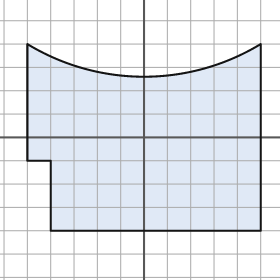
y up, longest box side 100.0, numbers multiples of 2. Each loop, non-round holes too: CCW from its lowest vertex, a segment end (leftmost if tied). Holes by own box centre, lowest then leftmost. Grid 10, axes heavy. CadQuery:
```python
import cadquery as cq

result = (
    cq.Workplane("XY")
    .moveTo(-40.0, -40.0)
    .lineTo(50.0, -40.0)
    .lineTo(50.0, 40.0)
    .threePointArc((0.0, 26.0), (-50.0, 40.0))
    .lineTo(-50.0, -10.0)
    .lineTo(-40.0, -10.0)
    .close()
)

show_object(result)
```